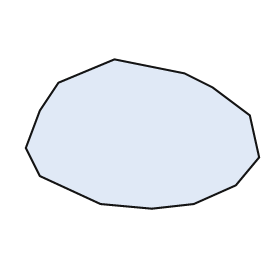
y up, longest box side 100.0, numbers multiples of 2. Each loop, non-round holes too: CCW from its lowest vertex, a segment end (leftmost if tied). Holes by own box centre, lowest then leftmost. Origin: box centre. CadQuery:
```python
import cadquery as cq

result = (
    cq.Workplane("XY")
    .moveTo(4.0, -32.0)
    .lineTo(22.0, -30.0)
    .lineTo(40.0, -22.0)
    .lineTo(50.0, -10.0)
    .lineTo(46.0, 8.0)
    .lineTo(30.0, 20.0)
    .lineTo(18.0, 26.0)
    .lineTo(-12.0, 32.0)
    .lineTo(-36.0, 22.0)
    .lineTo(-44.0, 10.0)
    .lineTo(-50.0, -6.0)
    .lineTo(-44.0, -18.0)
    .lineTo(-18.0, -30.0)
    .close()
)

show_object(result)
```